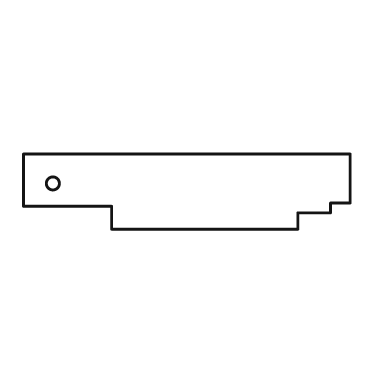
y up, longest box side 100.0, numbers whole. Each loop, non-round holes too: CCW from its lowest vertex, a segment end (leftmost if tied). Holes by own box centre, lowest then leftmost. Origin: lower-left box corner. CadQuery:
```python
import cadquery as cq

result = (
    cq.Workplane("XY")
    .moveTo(27.0, 0.0)
    .lineTo(84.0, 0.0)
    .lineTo(84.0, 5.0)
    .lineTo(94.0, 5.0)
    .lineTo(94.0, 8.0)
    .lineTo(100.0, 8.0)
    .lineTo(100.0, 23.0)
    .lineTo(0.0, 23.0)
    .lineTo(0.0, 7.0)
    .lineTo(27.0, 7.0)
    .close()
    .moveTo(9.0, 14.0)
    .circle(2.0)
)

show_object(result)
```